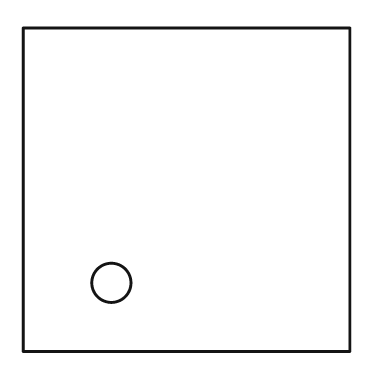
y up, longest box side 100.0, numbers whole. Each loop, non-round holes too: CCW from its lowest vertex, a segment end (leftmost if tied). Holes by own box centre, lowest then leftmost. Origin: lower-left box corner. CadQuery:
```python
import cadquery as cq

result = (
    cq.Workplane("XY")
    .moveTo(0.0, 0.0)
    .lineTo(100.0, 0.0)
    .lineTo(100.0, 99.0)
    .lineTo(0.0, 99.0)
    .close()
    .moveTo(27.0, 21.0)
    .circle(6.0)
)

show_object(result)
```